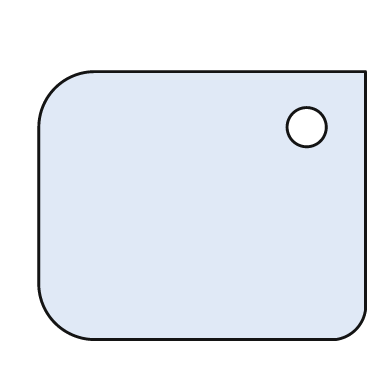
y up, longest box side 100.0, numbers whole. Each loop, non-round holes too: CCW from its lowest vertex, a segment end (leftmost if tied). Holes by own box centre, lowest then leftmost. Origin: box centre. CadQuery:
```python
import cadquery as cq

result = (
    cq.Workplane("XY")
    .moveTo(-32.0, -41.0)
    .lineTo(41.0, -41.0)
    .threePointArc((47.0, -38.0), (50.0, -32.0))
    .lineTo(50.0, 41.0)
    .lineTo(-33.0, 41.0)
    .threePointArc((-45.0, 36.0), (-50.0, 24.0))
    .lineTo(-50.0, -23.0)
    .threePointArc((-45.0, -36.0), (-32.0, -41.0))
    .close()
    .moveTo(32.0, 24.0)
    .circle(6.0)
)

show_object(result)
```